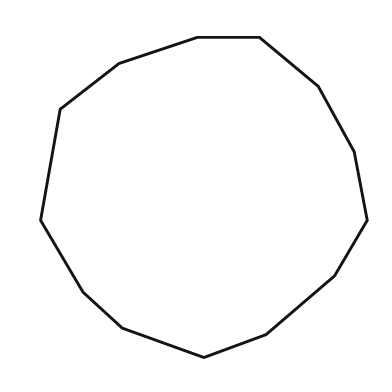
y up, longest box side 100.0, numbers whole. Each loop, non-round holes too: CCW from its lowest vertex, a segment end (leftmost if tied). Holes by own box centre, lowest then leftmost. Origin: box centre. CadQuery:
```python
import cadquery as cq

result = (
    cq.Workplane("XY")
    .moveTo(0.0, -49.0)
    .lineTo(19.0, -42.0)
    .lineTo(40.0, -24.0)
    .lineTo(50.0, -7.0)
    .lineTo(46.0, 14.0)
    .lineTo(35.0, 34.0)
    .lineTo(17.0, 49.0)
    .lineTo(-2.0, 49.0)
    .lineTo(-26.0, 41.0)
    .lineTo(-44.0, 27.0)
    .lineTo(-50.0, -7.0)
    .lineTo(-37.0, -29.0)
    .lineTo(-25.0, -40.0)
    .close()
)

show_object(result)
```